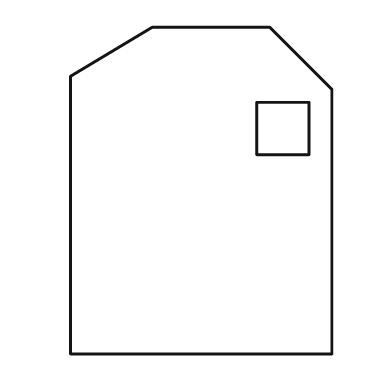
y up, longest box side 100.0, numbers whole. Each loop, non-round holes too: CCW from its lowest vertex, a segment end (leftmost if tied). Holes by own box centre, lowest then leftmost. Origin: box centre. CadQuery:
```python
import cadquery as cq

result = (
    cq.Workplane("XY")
    .moveTo(-40.0, -50.0)
    .lineTo(40.0, -50.0)
    .lineTo(40.0, 31.0)
    .lineTo(21.0, 50.0)
    .lineTo(-15.0, 50.0)
    .lineTo(-40.0, 35.0)
    .close()
    .moveTo(17.0, 11.0)
    .lineTo(33.0, 11.0)
    .lineTo(33.0, 27.0)
    .lineTo(17.0, 27.0)
    .close()
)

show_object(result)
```